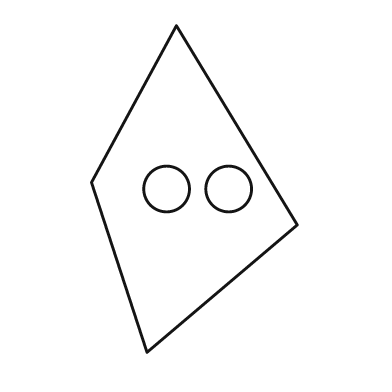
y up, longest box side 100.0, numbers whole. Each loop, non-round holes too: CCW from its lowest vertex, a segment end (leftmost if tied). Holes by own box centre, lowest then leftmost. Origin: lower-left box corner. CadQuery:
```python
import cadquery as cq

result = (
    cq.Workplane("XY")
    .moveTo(17.0, 0.0)
    .lineTo(63.0, 39.0)
    .lineTo(26.0, 100.0)
    .lineTo(0.0, 52.0)
    .close()
    .moveTo(23.0, 50.0)
    .circle(7.0)
    .moveTo(42.0, 50.0)
    .circle(7.0)
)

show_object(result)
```